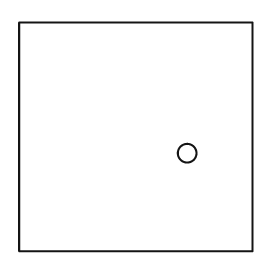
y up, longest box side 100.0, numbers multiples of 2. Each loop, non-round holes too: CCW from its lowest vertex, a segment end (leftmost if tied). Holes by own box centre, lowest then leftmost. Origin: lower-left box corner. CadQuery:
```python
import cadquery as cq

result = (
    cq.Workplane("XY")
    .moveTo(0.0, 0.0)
    .lineTo(100.0, 0.0)
    .lineTo(100.0, 98.0)
    .lineTo(0.0, 98.0)
    .close()
    .moveTo(72.0, 42.0)
    .circle(4.0)
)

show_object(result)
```